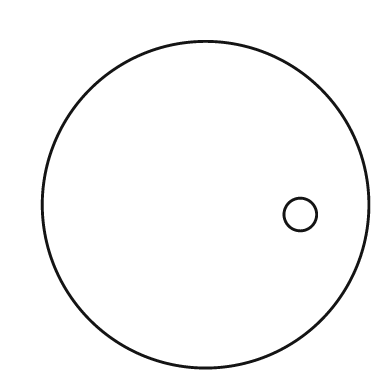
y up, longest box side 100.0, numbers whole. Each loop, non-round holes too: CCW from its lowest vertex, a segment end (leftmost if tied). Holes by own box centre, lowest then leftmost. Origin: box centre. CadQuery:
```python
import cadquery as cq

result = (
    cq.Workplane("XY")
    .moveTo(0.0, 0.0)
    .circle(50.0)
    .moveTo(29.0, -3.0)
    .circle(5.0)
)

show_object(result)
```